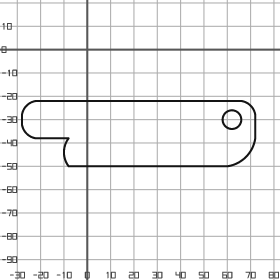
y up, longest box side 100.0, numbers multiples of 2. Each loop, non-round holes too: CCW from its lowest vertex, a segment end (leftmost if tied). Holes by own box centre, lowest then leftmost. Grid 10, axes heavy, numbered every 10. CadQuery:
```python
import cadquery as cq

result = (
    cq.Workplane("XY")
    .moveTo(-8.0, -50.0)
    .lineTo(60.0, -50.0)
    .threePointArc((68.0, -46.0), (72.0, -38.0))
    .lineTo(72.0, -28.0)
    .threePointArc((70.0, -24.0), (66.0, -22.0))
    .lineTo(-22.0, -22.0)
    .threePointArc((-26.0, -24.0), (-28.0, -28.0))
    .lineTo(-28.0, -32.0)
    .threePointArc((-26.0, -36.0), (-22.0, -38.0))
    .lineTo(-8.0, -38.0)
    .threePointArc((-10.0, -44.0), (-8.0, -50.0))
    .close()
    .moveTo(62.0, -30.0)
    .circle(4.0)
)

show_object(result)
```